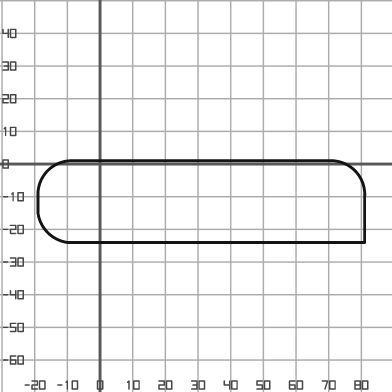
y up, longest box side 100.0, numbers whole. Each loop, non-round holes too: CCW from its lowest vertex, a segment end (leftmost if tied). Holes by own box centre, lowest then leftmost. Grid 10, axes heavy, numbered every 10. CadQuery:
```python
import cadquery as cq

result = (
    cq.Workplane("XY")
    .moveTo(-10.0, -24.0)
    .lineTo(81.0, -24.0)
    .lineTo(81.0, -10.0)
    .threePointArc((78.0, -2.0), (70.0, 1.0))
    .lineTo(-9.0, 1.0)
    .threePointArc((-16.0, -2.0), (-19.0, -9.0))
    .lineTo(-19.0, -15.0)
    .threePointArc((-16.0, -21.0), (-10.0, -24.0))
    .close()
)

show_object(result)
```